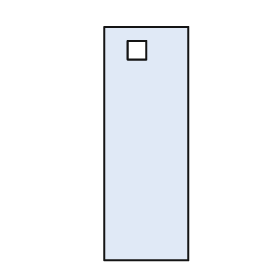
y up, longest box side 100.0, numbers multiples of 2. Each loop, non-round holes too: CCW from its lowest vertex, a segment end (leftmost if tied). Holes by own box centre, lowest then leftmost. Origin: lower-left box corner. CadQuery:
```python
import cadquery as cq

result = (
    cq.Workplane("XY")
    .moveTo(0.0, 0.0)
    .lineTo(36.0, 0.0)
    .lineTo(36.0, 100.0)
    .lineTo(0.0, 100.0)
    .close()
    .moveTo(10.0, 86.0)
    .lineTo(18.0, 86.0)
    .lineTo(18.0, 94.0)
    .lineTo(10.0, 94.0)
    .close()
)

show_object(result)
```